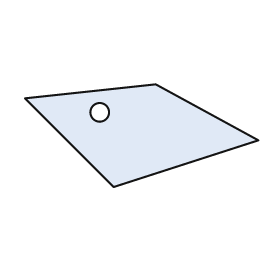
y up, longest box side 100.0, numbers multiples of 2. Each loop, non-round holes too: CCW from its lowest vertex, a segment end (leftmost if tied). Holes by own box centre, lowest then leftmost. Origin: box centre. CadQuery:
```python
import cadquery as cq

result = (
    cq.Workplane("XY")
    .moveTo(-12.0, -22.0)
    .lineTo(50.0, -2.0)
    .lineTo(6.0, 22.0)
    .lineTo(-50.0, 16.0)
    .close()
    .moveTo(-18.0, 10.0)
    .circle(4.0)
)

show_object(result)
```